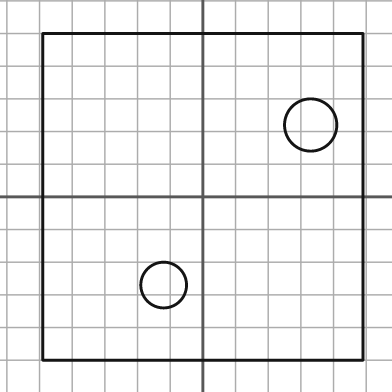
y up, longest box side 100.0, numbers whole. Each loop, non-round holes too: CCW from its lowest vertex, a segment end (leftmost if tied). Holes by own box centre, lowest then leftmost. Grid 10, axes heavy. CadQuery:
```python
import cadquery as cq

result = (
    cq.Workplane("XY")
    .moveTo(-49.0, -50.0)
    .lineTo(49.0, -50.0)
    .lineTo(49.0, 50.0)
    .lineTo(-49.0, 50.0)
    .close()
    .moveTo(-12.0, -27.0)
    .circle(7.0)
    .moveTo(33.0, 22.0)
    .circle(8.0)
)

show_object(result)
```